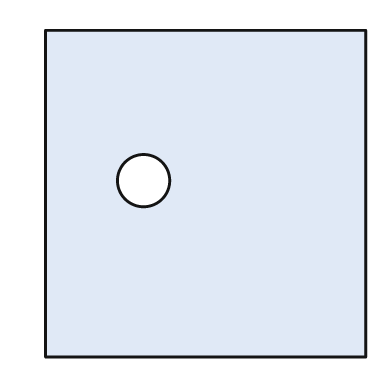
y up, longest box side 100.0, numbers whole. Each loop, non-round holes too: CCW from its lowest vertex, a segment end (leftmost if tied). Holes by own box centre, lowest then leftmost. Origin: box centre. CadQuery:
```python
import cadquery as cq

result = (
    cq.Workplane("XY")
    .moveTo(-49.0, -50.0)
    .lineTo(49.0, -50.0)
    .lineTo(49.0, 50.0)
    .lineTo(-49.0, 50.0)
    .close()
    .moveTo(-19.0, 4.0)
    .circle(8.0)
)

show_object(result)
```